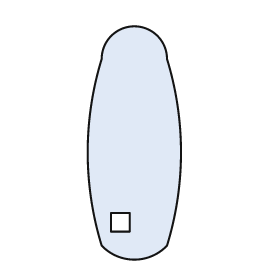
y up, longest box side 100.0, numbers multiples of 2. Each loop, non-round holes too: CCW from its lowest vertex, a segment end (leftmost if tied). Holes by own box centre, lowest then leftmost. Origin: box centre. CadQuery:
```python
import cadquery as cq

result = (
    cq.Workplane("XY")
    .moveTo(-14.0, -44.0)
    .threePointArc((0.0, -50.0), (14.0, -44.0))
    .threePointArc((20.0, -4.0), (14.0, 36.0))
    .threePointArc((0.0, 50.0), (-14.0, 36.0))
    .threePointArc((-20.0, -4.0), (-14.0, -44.0))
    .close()
    .moveTo(-10.0, -38.0)
    .lineTo(-2.0, -38.0)
    .lineTo(-2.0, -30.0)
    .lineTo(-10.0, -30.0)
    .close()
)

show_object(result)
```